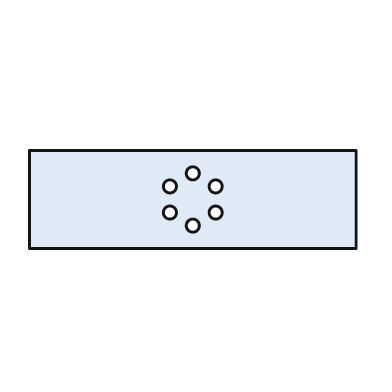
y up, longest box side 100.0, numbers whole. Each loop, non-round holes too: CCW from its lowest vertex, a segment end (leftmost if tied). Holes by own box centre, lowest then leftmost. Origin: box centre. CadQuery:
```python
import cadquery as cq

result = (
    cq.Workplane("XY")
    .moveTo(-50.0, -15.0)
    .lineTo(50.0, -15.0)
    .lineTo(50.0, 15.0)
    .lineTo(-50.0, 15.0)
    .close()
    .moveTo(0.0, -8.0)
    .circle(2.0)
    .moveTo(-7.0, -4.0)
    .circle(2.0)
    .moveTo(7.0, -4.0)
    .circle(2.0)
    .moveTo(-7.0, 4.0)
    .circle(2.0)
    .moveTo(7.0, 4.0)
    .circle(2.0)
    .moveTo(0.0, 8.0)
    .circle(2.0)
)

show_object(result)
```